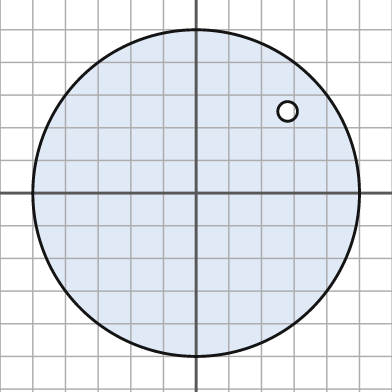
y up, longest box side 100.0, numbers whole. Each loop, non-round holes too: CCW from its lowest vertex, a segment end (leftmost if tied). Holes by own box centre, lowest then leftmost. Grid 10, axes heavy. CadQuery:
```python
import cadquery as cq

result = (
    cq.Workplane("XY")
    .moveTo(0.0, 0.0)
    .circle(50.0)
    .moveTo(28.0, 25.0)
    .circle(3.0)
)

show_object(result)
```